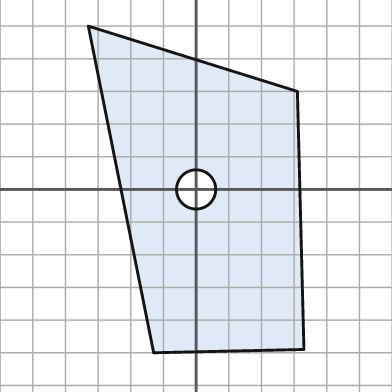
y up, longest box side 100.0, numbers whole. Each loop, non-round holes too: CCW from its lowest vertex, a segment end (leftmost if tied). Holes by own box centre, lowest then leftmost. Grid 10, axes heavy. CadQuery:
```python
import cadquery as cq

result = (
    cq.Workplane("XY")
    .moveTo(-13.0, -50.0)
    .lineTo(33.0, -49.0)
    .lineTo(31.0, 30.0)
    .lineTo(-33.0, 50.0)
    .close()
    .moveTo(0.0, 0.0)
    .circle(6.0)
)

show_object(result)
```